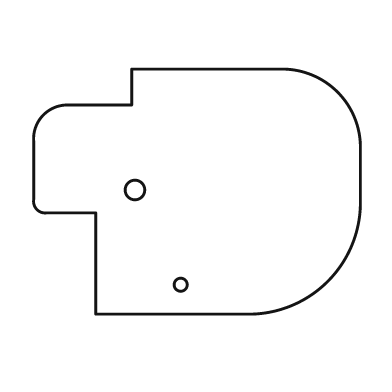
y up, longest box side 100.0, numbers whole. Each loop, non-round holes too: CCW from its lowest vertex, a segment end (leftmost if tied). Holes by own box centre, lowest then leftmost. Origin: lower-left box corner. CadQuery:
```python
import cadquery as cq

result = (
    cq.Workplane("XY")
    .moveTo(19.0, 0.0)
    .lineTo(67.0, 0.0)
    .threePointArc((90.0, 10.0), (100.0, 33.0))
    .lineTo(100.0, 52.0)
    .threePointArc((93.0, 68.0), (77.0, 75.0))
    .lineTo(30.0, 75.0)
    .lineTo(30.0, 64.0)
    .lineTo(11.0, 64.0)
    .threePointArc((3.0, 61.0), (0.0, 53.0))
    .lineTo(0.0, 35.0)
    .threePointArc((1.0, 32.0), (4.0, 31.0))
    .lineTo(19.0, 31.0)
    .close()
    .moveTo(45.0, 9.0)
    .circle(2.0)
    .moveTo(31.0, 38.0)
    .circle(3.0)
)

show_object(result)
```